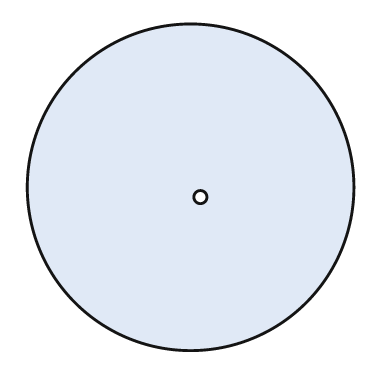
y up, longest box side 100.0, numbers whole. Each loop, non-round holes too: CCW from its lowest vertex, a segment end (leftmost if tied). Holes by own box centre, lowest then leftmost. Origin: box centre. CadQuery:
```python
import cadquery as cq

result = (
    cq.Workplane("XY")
    .moveTo(0.0, 0.0)
    .circle(50.0)
    .moveTo(3.0, -3.0)
    .circle(2.0)
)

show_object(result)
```